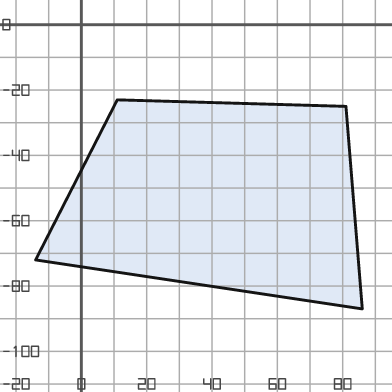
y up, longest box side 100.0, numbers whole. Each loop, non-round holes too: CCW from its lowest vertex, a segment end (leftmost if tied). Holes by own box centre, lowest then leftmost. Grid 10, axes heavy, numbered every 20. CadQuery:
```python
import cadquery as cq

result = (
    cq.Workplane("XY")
    .moveTo(86.0, -87.0)
    .lineTo(81.0, -25.0)
    .lineTo(11.0, -23.0)
    .lineTo(-14.0, -72.0)
    .close()
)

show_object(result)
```